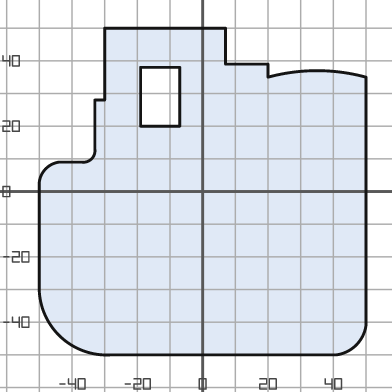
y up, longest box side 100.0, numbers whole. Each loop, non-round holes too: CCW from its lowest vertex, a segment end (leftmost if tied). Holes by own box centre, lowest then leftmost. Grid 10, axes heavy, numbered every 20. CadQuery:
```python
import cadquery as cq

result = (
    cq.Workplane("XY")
    .moveTo(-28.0, -50.0)
    .lineTo(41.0, -50.0)
    .threePointArc((47.0, -47.0), (50.0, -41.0))
    .lineTo(50.0, 35.0)
    .threePointArc((35.0, 37.0), (20.0, 35.0))
    .lineTo(20.0, 39.0)
    .lineTo(7.0, 39.0)
    .lineTo(7.0, 50.0)
    .lineTo(-30.0, 50.0)
    .lineTo(-30.0, 28.0)
    .lineTo(-33.0, 28.0)
    .lineTo(-33.0, 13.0)
    .threePointArc((-34.0, 10.0), (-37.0, 9.0))
    .lineTo(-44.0, 9.0)
    .threePointArc((-48.0, 7.0), (-50.0, 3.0))
    .lineTo(-50.0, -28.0)
    .threePointArc((-44.0, -44.0), (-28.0, -50.0))
    .close()
    .moveTo(-19.0, 20.0)
    .lineTo(-7.0, 20.0)
    .lineTo(-7.0, 38.0)
    .lineTo(-19.0, 38.0)
    .close()
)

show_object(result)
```